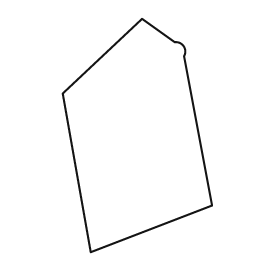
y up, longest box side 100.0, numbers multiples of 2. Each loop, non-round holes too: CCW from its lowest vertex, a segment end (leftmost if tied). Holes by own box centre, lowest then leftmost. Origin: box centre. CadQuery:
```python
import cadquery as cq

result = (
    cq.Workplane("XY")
    .moveTo(-20.0, -50.0)
    .lineTo(32.0, -30.0)
    .lineTo(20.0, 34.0)
    .threePointArc((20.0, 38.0), (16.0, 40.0))
    .lineTo(2.0, 50.0)
    .lineTo(-32.0, 18.0)
    .close()
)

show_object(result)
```